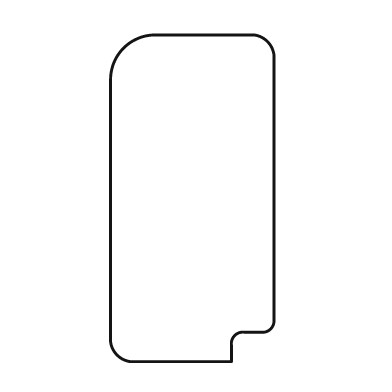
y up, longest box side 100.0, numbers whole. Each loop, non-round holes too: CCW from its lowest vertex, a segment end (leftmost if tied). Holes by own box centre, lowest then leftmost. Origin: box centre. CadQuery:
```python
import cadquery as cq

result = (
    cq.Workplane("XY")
    .moveTo(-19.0, -50.0)
    .lineTo(12.0, -50.0)
    .lineTo(12.0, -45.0)
    .threePointArc((13.0, -42.0), (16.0, -41.0))
    .lineTo(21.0, -41.0)
    .threePointArc((24.0, -40.0), (25.0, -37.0))
    .lineTo(25.0, 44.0)
    .threePointArc((23.0, 48.0), (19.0, 50.0))
    .lineTo(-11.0, 50.0)
    .threePointArc((-21.0, 46.0), (-25.0, 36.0))
    .lineTo(-25.0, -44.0)
    .threePointArc((-23.0, -48.0), (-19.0, -50.0))
    .close()
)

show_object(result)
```